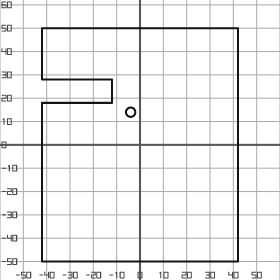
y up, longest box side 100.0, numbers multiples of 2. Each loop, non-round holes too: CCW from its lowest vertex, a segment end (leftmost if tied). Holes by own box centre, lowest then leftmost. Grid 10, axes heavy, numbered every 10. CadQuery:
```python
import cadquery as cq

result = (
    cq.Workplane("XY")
    .moveTo(-42.0, -50.0)
    .lineTo(42.0, -50.0)
    .lineTo(42.0, 50.0)
    .lineTo(-42.0, 50.0)
    .lineTo(-42.0, 28.0)
    .lineTo(-12.0, 28.0)
    .lineTo(-12.0, 18.0)
    .lineTo(-42.0, 18.0)
    .close()
    .moveTo(-4.0, 14.0)
    .circle(2.0)
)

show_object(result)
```